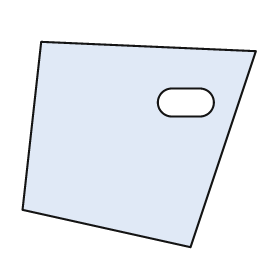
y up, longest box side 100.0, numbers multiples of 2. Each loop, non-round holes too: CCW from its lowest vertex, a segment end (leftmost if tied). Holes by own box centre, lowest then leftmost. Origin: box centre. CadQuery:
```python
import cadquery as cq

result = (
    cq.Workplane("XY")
    .moveTo(22.0, -44.0)
    .lineTo(50.0, 40.0)
    .lineTo(-42.0, 44.0)
    .lineTo(-50.0, -28.0)
    .close()
    .moveTo(14.0, 12.0)
    .lineTo(26.0, 12.0)
    .threePointArc((32.0, 18.0), (26.0, 24.0))
    .lineTo(14.0, 24.0)
    .threePointArc((8.0, 18.0), (14.0, 12.0))
    .close()
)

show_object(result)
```